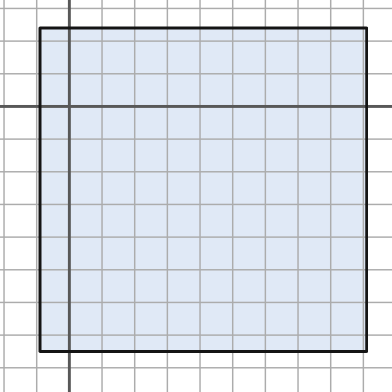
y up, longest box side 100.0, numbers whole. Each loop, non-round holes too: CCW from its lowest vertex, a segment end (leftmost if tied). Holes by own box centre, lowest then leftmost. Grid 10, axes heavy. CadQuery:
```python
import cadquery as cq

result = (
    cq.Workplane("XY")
    .moveTo(-9.0, -75.0)
    .lineTo(91.0, -75.0)
    .lineTo(91.0, 24.0)
    .lineTo(-9.0, 24.0)
    .close()
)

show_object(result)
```